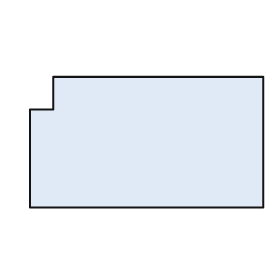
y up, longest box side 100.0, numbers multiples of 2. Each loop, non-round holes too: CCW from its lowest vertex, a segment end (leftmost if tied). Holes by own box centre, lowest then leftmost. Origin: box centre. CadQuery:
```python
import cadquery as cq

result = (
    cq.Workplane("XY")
    .moveTo(-50.0, -28.0)
    .lineTo(50.0, -28.0)
    .lineTo(50.0, 28.0)
    .lineTo(-40.0, 28.0)
    .lineTo(-40.0, 14.0)
    .lineTo(-50.0, 14.0)
    .close()
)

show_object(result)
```